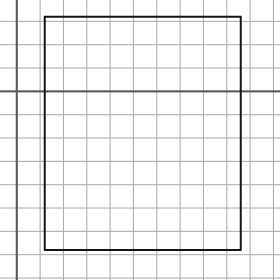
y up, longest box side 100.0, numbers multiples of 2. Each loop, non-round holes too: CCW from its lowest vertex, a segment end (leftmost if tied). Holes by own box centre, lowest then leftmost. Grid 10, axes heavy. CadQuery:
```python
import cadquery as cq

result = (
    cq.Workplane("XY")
    .moveTo(12.0, -68.0)
    .lineTo(96.0, -68.0)
    .lineTo(96.0, 32.0)
    .lineTo(12.0, 32.0)
    .close()
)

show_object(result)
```